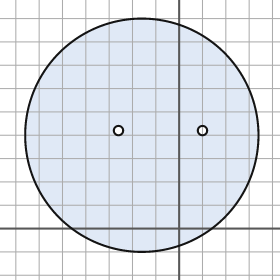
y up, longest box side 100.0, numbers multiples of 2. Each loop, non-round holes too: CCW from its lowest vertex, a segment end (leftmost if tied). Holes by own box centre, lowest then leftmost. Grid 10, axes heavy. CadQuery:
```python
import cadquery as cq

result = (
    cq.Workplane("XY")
    .moveTo(-16.0, 40.0)
    .circle(50.0)
    .moveTo(-26.0, 42.0)
    .circle(2.0)
    .moveTo(10.0, 42.0)
    .circle(2.0)
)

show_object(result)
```